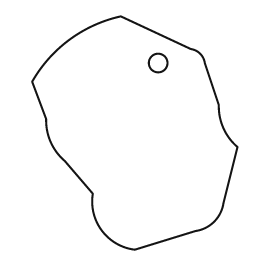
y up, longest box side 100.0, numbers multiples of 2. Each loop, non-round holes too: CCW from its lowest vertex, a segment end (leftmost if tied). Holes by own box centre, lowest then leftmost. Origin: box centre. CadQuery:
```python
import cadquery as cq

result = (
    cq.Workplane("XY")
    .moveTo(0.0, -50.0)
    .lineTo(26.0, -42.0)
    .threePointArc((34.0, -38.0), (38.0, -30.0))
    .lineTo(44.0, -6.0)
    .threePointArc((38.0, 2.0), (36.0, 12.0))
    .lineTo(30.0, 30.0)
    .threePointArc((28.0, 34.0), (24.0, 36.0))
    .lineTo(-6.0, 50.0)
    .threePointArc((-28.0, 40.0), (-44.0, 22.0))
    .lineTo(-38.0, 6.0)
    .threePointArc((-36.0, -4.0), (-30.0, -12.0))
    .lineTo(-18.0, -26.0)
    .threePointArc((-14.0, -42.0), (0.0, -50.0))
    .close()
    .moveTo(10.0, 30.0)
    .circle(4.0)
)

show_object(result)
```